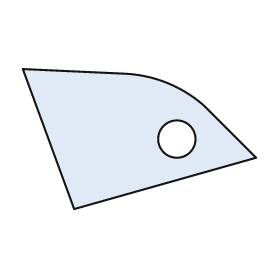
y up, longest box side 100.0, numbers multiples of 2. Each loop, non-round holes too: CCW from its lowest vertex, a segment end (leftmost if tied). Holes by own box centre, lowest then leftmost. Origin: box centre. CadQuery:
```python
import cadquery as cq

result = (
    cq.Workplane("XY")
    .moveTo(-28.0, -30.0)
    .lineTo(50.0, -8.0)
    .lineTo(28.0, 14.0)
    .threePointArc((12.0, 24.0), (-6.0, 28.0))
    .lineTo(-50.0, 30.0)
    .close()
    .moveTo(16.0, 0.0)
    .circle(8.0)
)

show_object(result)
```